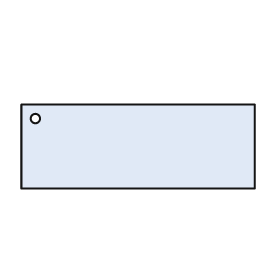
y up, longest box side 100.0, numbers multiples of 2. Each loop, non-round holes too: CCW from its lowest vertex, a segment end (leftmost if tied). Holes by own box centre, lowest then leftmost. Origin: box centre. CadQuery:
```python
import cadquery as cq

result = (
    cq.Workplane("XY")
    .moveTo(-50.0, -18.0)
    .lineTo(50.0, -18.0)
    .lineTo(50.0, 18.0)
    .lineTo(-50.0, 18.0)
    .close()
    .moveTo(-44.0, 12.0)
    .circle(2.0)
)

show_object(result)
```